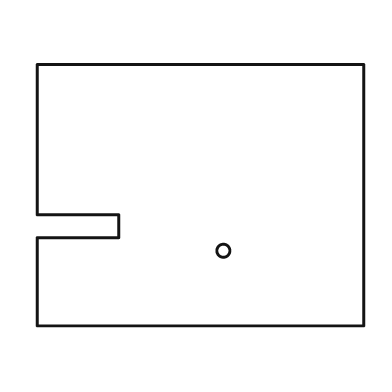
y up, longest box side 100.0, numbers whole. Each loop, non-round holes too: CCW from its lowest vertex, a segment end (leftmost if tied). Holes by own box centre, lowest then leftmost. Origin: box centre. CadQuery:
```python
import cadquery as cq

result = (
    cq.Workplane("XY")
    .moveTo(-50.0, -40.0)
    .lineTo(50.0, -40.0)
    .lineTo(50.0, 40.0)
    .lineTo(-50.0, 40.0)
    .lineTo(-50.0, -6.0)
    .lineTo(-25.0, -6.0)
    .lineTo(-25.0, -13.0)
    .lineTo(-50.0, -13.0)
    .close()
    .moveTo(7.0, -17.0)
    .circle(2.0)
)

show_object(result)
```